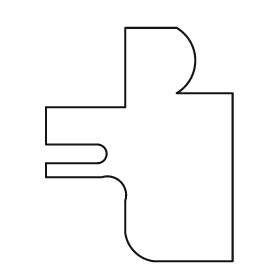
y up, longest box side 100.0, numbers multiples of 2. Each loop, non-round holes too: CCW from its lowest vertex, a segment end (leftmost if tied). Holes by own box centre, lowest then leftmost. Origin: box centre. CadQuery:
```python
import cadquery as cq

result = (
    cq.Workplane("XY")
    .moveTo(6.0, -50.0)
    .lineTo(40.0, -50.0)
    .lineTo(40.0, 22.0)
    .lineTo(16.0, 22.0)
    .threePointArc((24.0, 36.0), (16.0, 50.0))
    .lineTo(-6.0, 50.0)
    .lineTo(-6.0, 16.0)
    .lineTo(-40.0, 16.0)
    .lineTo(-40.0, 0.0)
    .lineTo(-18.0, 0.0)
    .threePointArc((-14.0, -4.0), (-18.0, -8.0))
    .lineTo(-40.0, -8.0)
    .lineTo(-40.0, -14.0)
    .lineTo(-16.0, -14.0)
    .threePointArc((-8.0, -16.0), (-6.0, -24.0))
    .lineTo(-6.0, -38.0)
    .threePointArc((-2.0, -46.0), (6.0, -50.0))
    .close()
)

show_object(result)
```